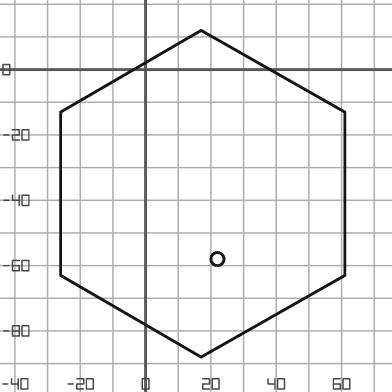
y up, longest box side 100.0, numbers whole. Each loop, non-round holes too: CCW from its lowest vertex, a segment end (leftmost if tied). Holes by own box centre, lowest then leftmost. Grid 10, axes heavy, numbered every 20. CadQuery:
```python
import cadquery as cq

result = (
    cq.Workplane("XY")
    .moveTo(17.0, -88.0)
    .lineTo(61.0, -63.0)
    .lineTo(61.0, -13.0)
    .lineTo(17.0, 12.0)
    .lineTo(-26.0, -13.0)
    .lineTo(-26.0, -63.0)
    .close()
    .moveTo(22.0, -58.0)
    .circle(2.0)
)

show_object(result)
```